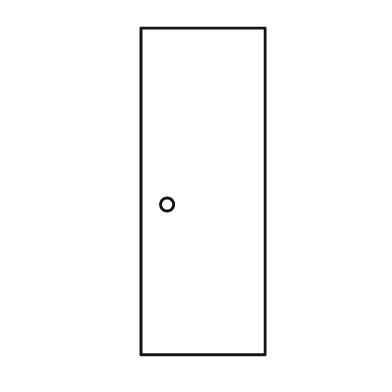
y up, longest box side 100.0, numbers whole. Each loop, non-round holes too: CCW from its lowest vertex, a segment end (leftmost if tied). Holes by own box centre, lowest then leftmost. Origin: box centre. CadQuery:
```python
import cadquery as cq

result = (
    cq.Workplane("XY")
    .moveTo(-19.0, -50.0)
    .lineTo(19.0, -50.0)
    .lineTo(19.0, 50.0)
    .lineTo(-19.0, 50.0)
    .close()
    .moveTo(-11.0, -4.0)
    .circle(2.0)
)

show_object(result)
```